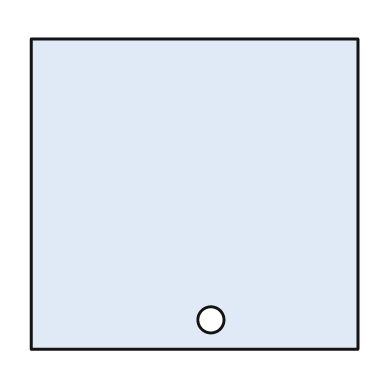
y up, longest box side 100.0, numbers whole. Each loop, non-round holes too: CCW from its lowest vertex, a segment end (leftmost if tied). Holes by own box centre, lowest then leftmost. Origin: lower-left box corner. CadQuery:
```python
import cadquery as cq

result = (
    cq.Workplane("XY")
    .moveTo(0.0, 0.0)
    .lineTo(100.0, 0.0)
    .lineTo(100.0, 95.0)
    .lineTo(0.0, 95.0)
    .close()
    .moveTo(55.0, 9.0)
    .circle(4.0)
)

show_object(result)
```